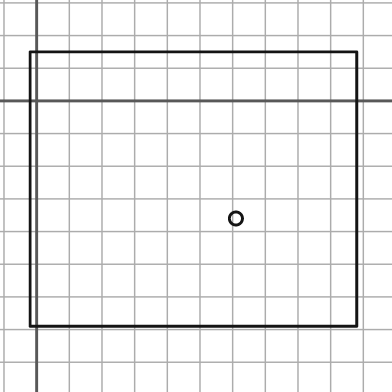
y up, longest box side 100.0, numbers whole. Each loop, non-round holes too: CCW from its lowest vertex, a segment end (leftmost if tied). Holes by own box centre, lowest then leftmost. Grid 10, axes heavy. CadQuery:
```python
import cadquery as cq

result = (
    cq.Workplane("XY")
    .moveTo(-2.0, -69.0)
    .lineTo(98.0, -69.0)
    .lineTo(98.0, 15.0)
    .lineTo(-2.0, 15.0)
    .close()
    .moveTo(61.0, -36.0)
    .circle(2.0)
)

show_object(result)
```